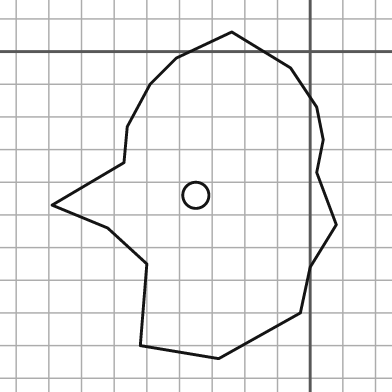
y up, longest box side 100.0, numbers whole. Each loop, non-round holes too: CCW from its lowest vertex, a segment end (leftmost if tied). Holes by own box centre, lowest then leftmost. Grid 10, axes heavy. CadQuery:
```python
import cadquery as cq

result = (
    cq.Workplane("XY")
    .moveTo(-28.0, -94.0)
    .lineTo(-3.0, -80.0)
    .lineTo(0.0, -66.0)
    .lineTo(8.0, -53.0)
    .lineTo(2.0, -37.0)
    .lineTo(4.0, -27.0)
    .lineTo(2.0, -17.0)
    .lineTo(-6.0, -5.0)
    .lineTo(-24.0, 6.0)
    .lineTo(-41.0, -2.0)
    .lineTo(-49.0, -10.0)
    .lineTo(-56.0, -23.0)
    .lineTo(-57.0, -34.0)
    .lineTo(-79.0, -47.0)
    .lineTo(-62.0, -54.0)
    .lineTo(-50.0, -65.0)
    .lineTo(-52.0, -90.0)
    .close()
    .moveTo(-35.0, -44.0)
    .circle(4.0)
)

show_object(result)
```